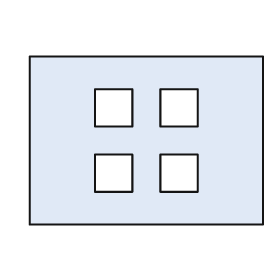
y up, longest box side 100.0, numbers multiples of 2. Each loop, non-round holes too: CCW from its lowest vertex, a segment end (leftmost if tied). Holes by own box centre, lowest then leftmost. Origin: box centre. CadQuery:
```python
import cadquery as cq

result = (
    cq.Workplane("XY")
    .moveTo(-50.0, -36.0)
    .lineTo(50.0, -36.0)
    .lineTo(50.0, 36.0)
    .lineTo(-50.0, 36.0)
    .close()
    .moveTo(-22.0, -22.0)
    .lineTo(-6.0, -22.0)
    .lineTo(-6.0, -6.0)
    .lineTo(-22.0, -6.0)
    .close()
    .moveTo(6.0, -22.0)
    .lineTo(22.0, -22.0)
    .lineTo(22.0, -6.0)
    .lineTo(6.0, -6.0)
    .close()
    .moveTo(-22.0, 6.0)
    .lineTo(-6.0, 6.0)
    .lineTo(-6.0, 22.0)
    .lineTo(-22.0, 22.0)
    .close()
    .moveTo(6.0, 6.0)
    .lineTo(22.0, 6.0)
    .lineTo(22.0, 22.0)
    .lineTo(6.0, 22.0)
    .close()
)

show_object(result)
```